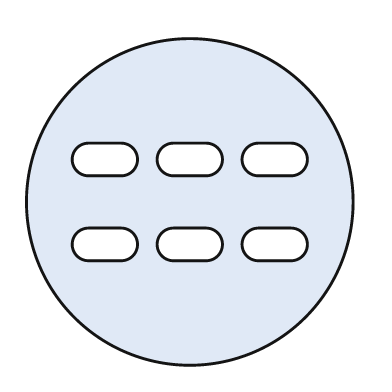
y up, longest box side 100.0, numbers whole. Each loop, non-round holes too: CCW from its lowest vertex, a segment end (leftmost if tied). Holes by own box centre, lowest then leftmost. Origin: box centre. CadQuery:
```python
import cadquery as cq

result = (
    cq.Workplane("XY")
    .moveTo(0.0, 0.0)
    .circle(50.0)
    .moveTo(-31.0, -18.0)
    .lineTo(-21.0, -18.0)
    .threePointArc((-16.0, -13.0), (-21.0, -8.0))
    .lineTo(-31.0, -8.0)
    .threePointArc((-36.0, -13.0), (-31.0, -18.0))
    .close()
    .moveTo(-5.0, -18.0)
    .lineTo(5.0, -18.0)
    .threePointArc((10.0, -13.0), (5.0, -8.0))
    .lineTo(-5.0, -8.0)
    .threePointArc((-10.0, -13.0), (-5.0, -18.0))
    .close()
    .moveTo(21.0, -18.0)
    .lineTo(31.0, -18.0)
    .threePointArc((36.0, -13.0), (31.0, -8.0))
    .lineTo(21.0, -8.0)
    .threePointArc((16.0, -13.0), (21.0, -18.0))
    .close()
    .moveTo(-31.0, 8.0)
    .lineTo(-21.0, 8.0)
    .threePointArc((-16.0, 13.0), (-21.0, 18.0))
    .lineTo(-31.0, 18.0)
    .threePointArc((-36.0, 13.0), (-31.0, 8.0))
    .close()
    .moveTo(-5.0, 8.0)
    .lineTo(5.0, 8.0)
    .threePointArc((10.0, 13.0), (5.0, 18.0))
    .lineTo(-5.0, 18.0)
    .threePointArc((-10.0, 13.0), (-5.0, 8.0))
    .close()
    .moveTo(21.0, 8.0)
    .lineTo(31.0, 8.0)
    .threePointArc((36.0, 13.0), (31.0, 18.0))
    .lineTo(21.0, 18.0)
    .threePointArc((16.0, 13.0), (21.0, 8.0))
    .close()
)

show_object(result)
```